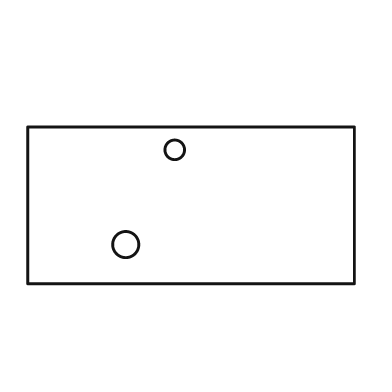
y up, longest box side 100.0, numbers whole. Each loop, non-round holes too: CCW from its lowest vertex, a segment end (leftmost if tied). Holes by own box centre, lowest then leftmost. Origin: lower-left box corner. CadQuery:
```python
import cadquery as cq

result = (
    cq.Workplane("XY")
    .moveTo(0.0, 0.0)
    .lineTo(100.0, 0.0)
    .lineTo(100.0, 48.0)
    .lineTo(0.0, 48.0)
    .close()
    .moveTo(30.0, 12.0)
    .circle(4.0)
    .moveTo(45.0, 41.0)
    .circle(3.0)
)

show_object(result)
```